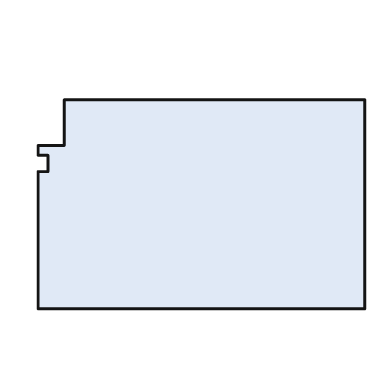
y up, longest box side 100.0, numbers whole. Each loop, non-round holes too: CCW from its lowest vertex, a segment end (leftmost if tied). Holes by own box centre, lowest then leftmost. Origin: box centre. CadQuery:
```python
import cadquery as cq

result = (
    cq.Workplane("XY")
    .moveTo(-50.0, -32.0)
    .lineTo(50.0, -32.0)
    .lineTo(50.0, 32.0)
    .lineTo(-42.0, 32.0)
    .lineTo(-42.0, 18.0)
    .lineTo(-50.0, 18.0)
    .lineTo(-50.0, 15.0)
    .lineTo(-47.0, 15.0)
    .lineTo(-47.0, 10.0)
    .lineTo(-50.0, 10.0)
    .close()
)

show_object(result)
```